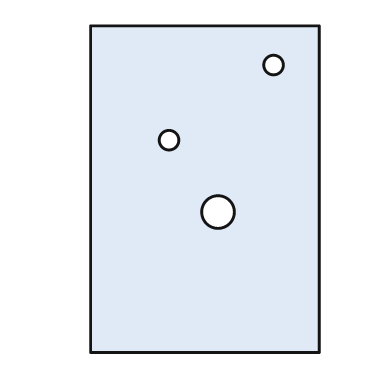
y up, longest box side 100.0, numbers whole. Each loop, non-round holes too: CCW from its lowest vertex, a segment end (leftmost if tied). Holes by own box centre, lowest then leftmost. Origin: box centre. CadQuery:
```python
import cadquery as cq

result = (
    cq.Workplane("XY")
    .moveTo(-35.0, -50.0)
    .lineTo(35.0, -50.0)
    .lineTo(35.0, 50.0)
    .lineTo(-35.0, 50.0)
    .close()
    .moveTo(4.0, -7.0)
    .circle(5.0)
    .moveTo(-11.0, 15.0)
    .circle(3.0)
    .moveTo(21.0, 38.0)
    .circle(3.0)
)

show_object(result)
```